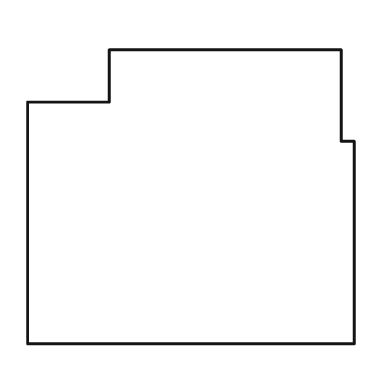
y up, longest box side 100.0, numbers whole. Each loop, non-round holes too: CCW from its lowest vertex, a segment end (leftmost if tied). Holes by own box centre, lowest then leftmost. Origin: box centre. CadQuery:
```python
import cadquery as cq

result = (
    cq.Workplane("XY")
    .moveTo(-50.0, -45.0)
    .lineTo(50.0, -45.0)
    .lineTo(50.0, 17.0)
    .lineTo(46.0, 17.0)
    .lineTo(46.0, 45.0)
    .lineTo(-25.0, 45.0)
    .lineTo(-25.0, 29.0)
    .lineTo(-50.0, 29.0)
    .close()
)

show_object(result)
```